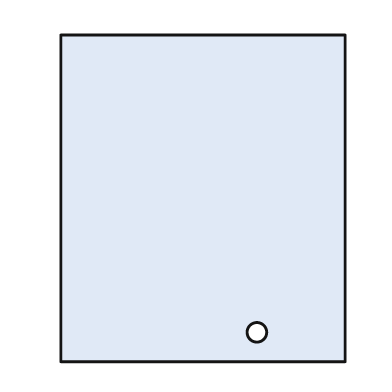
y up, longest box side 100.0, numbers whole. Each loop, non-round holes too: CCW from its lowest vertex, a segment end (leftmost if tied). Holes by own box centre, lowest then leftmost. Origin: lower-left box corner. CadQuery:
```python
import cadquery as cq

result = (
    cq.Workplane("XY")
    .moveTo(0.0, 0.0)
    .lineTo(87.0, 0.0)
    .lineTo(87.0, 100.0)
    .lineTo(0.0, 100.0)
    .close()
    .moveTo(60.0, 9.0)
    .circle(3.0)
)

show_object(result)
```